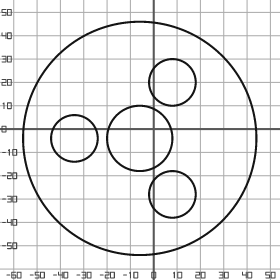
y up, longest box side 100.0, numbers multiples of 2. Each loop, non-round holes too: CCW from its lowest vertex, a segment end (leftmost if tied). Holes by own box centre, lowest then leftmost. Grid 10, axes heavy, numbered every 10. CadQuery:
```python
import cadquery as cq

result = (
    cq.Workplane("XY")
    .moveTo(-6.0, -4.0)
    .circle(50.0)
    .moveTo(8.0, -28.0)
    .circle(10.0)
    .moveTo(-34.0, -4.0)
    .circle(10.0)
    .moveTo(-6.0, -4.0)
    .circle(14.0)
    .moveTo(8.0, 20.0)
    .circle(10.0)
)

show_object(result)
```